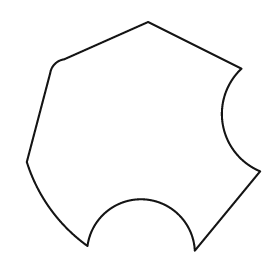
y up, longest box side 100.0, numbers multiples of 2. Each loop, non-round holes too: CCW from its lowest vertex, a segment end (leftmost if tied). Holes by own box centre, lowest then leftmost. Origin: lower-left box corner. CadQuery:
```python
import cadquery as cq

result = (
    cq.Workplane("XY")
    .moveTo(72.0, 0.0)
    .lineTo(100.0, 34.0)
    .threePointArc((84.0, 54.0), (92.0, 78.0))
    .lineTo(52.0, 98.0)
    .lineTo(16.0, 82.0)
    .threePointArc((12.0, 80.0), (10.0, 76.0))
    .lineTo(0.0, 38.0)
    .threePointArc((10.0, 18.0), (26.0, 2.0))
    .threePointArc((50.0, 22.0), (72.0, 0.0))
    .close()
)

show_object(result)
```